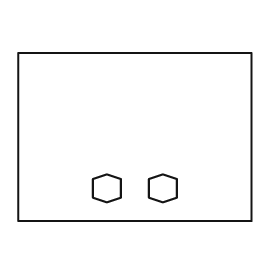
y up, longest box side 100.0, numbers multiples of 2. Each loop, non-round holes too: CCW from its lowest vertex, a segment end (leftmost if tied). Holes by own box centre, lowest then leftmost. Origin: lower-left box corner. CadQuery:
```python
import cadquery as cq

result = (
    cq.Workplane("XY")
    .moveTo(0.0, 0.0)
    .lineTo(100.0, 0.0)
    .lineTo(100.0, 72.0)
    .lineTo(0.0, 72.0)
    .close()
    .moveTo(38.0, 8.0)
    .lineTo(44.0, 10.0)
    .lineTo(44.0, 18.0)
    .lineTo(38.0, 20.0)
    .lineTo(32.0, 18.0)
    .lineTo(32.0, 10.0)
    .close()
    .moveTo(62.0, 8.0)
    .lineTo(68.0, 10.0)
    .lineTo(68.0, 18.0)
    .lineTo(62.0, 20.0)
    .lineTo(56.0, 18.0)
    .lineTo(56.0, 10.0)
    .close()
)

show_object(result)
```